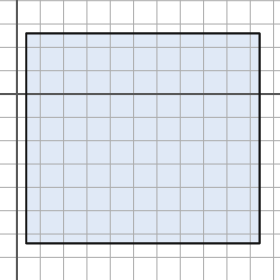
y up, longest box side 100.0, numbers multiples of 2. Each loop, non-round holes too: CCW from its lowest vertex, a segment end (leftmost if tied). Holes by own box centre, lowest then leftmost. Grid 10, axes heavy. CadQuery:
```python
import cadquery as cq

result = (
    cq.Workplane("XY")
    .moveTo(4.0, -64.0)
    .lineTo(104.0, -64.0)
    .lineTo(104.0, 26.0)
    .lineTo(4.0, 26.0)
    .close()
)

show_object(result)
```